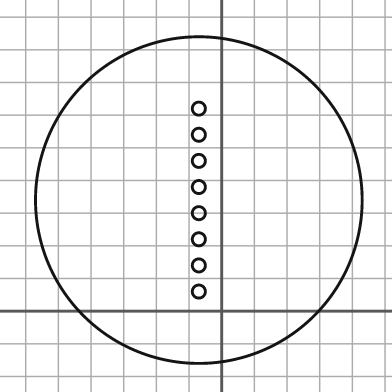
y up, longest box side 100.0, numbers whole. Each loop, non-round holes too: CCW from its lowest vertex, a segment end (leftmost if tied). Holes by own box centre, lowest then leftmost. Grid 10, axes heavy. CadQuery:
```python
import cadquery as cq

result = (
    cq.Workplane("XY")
    .moveTo(-7.0, 34.0)
    .circle(50.0)
    .moveTo(-7.0, 6.0)
    .circle(2.0)
    .moveTo(-7.0, 14.0)
    .circle(2.0)
    .moveTo(-7.0, 22.0)
    .circle(2.0)
    .moveTo(-7.0, 30.0)
    .circle(2.0)
    .moveTo(-7.0, 38.0)
    .circle(2.0)
    .moveTo(-7.0, 46.0)
    .circle(2.0)
    .moveTo(-7.0, 54.0)
    .circle(2.0)
    .moveTo(-7.0, 62.0)
    .circle(2.0)
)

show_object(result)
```